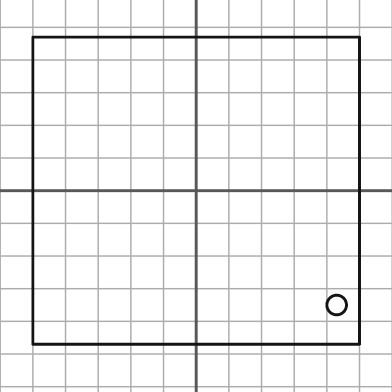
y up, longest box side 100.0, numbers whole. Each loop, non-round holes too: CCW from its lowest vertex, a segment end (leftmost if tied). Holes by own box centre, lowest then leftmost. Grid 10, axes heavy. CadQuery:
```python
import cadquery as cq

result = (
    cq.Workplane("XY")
    .moveTo(-50.0, -47.0)
    .lineTo(50.0, -47.0)
    .lineTo(50.0, 47.0)
    .lineTo(-50.0, 47.0)
    .close()
    .moveTo(43.0, -35.0)
    .circle(3.0)
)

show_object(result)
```